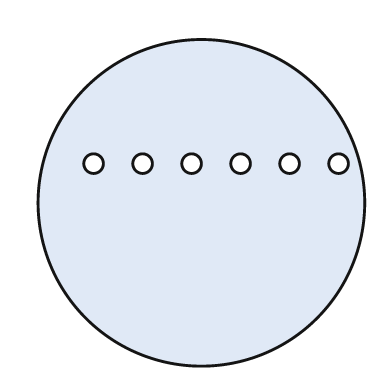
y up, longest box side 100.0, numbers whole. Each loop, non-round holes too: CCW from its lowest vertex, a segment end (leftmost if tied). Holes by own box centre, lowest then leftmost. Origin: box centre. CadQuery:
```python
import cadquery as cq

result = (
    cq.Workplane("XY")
    .moveTo(0.0, 0.0)
    .circle(50.0)
    .moveTo(-33.0, 12.0)
    .circle(3.0)
    .moveTo(-18.0, 12.0)
    .circle(3.0)
    .moveTo(-3.0, 12.0)
    .circle(3.0)
    .moveTo(12.0, 12.0)
    .circle(3.0)
    .moveTo(27.0, 12.0)
    .circle(3.0)
    .moveTo(42.0, 12.0)
    .circle(3.0)
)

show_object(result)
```